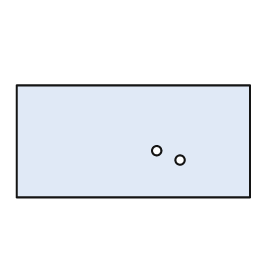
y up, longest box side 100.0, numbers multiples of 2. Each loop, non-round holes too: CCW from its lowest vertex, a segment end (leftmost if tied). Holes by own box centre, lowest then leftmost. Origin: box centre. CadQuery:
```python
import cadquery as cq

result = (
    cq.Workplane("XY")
    .moveTo(-50.0, -24.0)
    .lineTo(50.0, -24.0)
    .lineTo(50.0, 24.0)
    .lineTo(-50.0, 24.0)
    .close()
    .moveTo(20.0, -8.0)
    .circle(2.0)
    .moveTo(10.0, -4.0)
    .circle(2.0)
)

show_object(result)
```